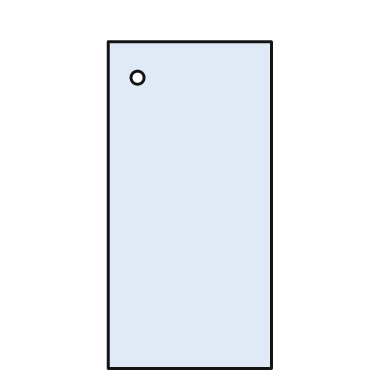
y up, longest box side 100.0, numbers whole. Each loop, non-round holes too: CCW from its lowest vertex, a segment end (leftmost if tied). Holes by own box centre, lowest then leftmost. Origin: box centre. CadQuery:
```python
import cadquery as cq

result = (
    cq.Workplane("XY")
    .moveTo(-25.0, -50.0)
    .lineTo(25.0, -50.0)
    .lineTo(25.0, 50.0)
    .lineTo(-25.0, 50.0)
    .close()
    .moveTo(-16.0, 39.0)
    .circle(2.0)
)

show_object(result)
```